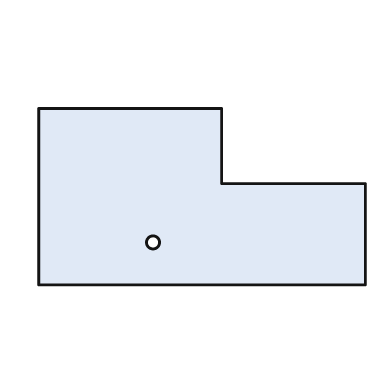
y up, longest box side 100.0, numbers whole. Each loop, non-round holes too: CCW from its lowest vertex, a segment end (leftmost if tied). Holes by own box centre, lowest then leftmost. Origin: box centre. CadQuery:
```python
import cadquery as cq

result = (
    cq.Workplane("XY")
    .moveTo(-50.0, -27.0)
    .lineTo(50.0, -27.0)
    .lineTo(50.0, 4.0)
    .lineTo(6.0, 4.0)
    .lineTo(6.0, 27.0)
    .lineTo(-50.0, 27.0)
    .close()
    .moveTo(-15.0, -14.0)
    .circle(2.0)
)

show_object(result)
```